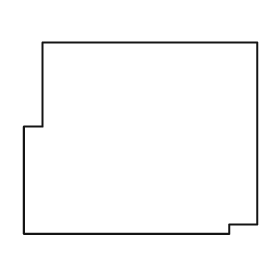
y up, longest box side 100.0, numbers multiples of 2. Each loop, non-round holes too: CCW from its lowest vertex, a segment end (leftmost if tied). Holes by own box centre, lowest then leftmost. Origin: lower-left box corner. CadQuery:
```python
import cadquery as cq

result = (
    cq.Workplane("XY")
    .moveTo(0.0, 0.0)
    .lineTo(88.0, 0.0)
    .lineTo(88.0, 4.0)
    .lineTo(100.0, 4.0)
    .lineTo(100.0, 82.0)
    .lineTo(8.0, 82.0)
    .lineTo(8.0, 46.0)
    .lineTo(0.0, 46.0)
    .close()
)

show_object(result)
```